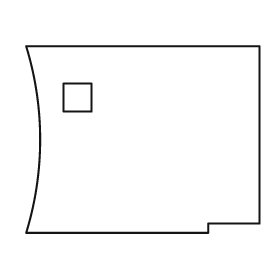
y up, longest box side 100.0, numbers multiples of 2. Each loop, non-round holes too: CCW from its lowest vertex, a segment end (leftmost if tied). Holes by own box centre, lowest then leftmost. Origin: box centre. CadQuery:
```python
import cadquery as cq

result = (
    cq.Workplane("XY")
    .moveTo(-50.0, -40.0)
    .lineTo(28.0, -40.0)
    .lineTo(28.0, -36.0)
    .lineTo(50.0, -36.0)
    .lineTo(50.0, 40.0)
    .lineTo(-50.0, 40.0)
    .threePointArc((-44.0, 0.0), (-50.0, -40.0))
    .close()
    .moveTo(-34.0, 12.0)
    .lineTo(-22.0, 12.0)
    .lineTo(-22.0, 24.0)
    .lineTo(-34.0, 24.0)
    .close()
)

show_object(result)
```